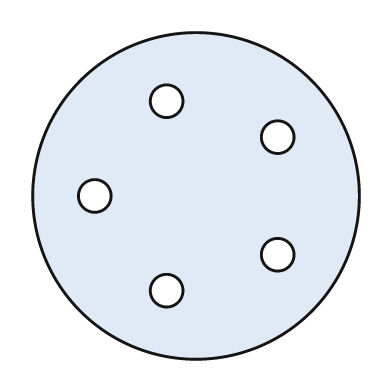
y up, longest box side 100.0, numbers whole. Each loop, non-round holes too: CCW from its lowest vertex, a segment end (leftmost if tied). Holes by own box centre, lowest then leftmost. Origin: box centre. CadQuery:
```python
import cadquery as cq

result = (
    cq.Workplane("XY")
    .moveTo(0.0, 0.0)
    .circle(50.0)
    .moveTo(-9.0, -29.0)
    .circle(5.0)
    .moveTo(25.0, -18.0)
    .circle(5.0)
    .moveTo(-31.0, 0.0)
    .circle(5.0)
    .moveTo(25.0, 18.0)
    .circle(5.0)
    .moveTo(-9.0, 29.0)
    .circle(5.0)
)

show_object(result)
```